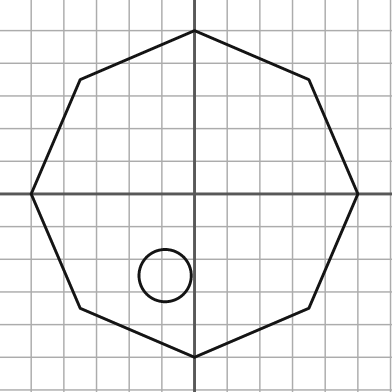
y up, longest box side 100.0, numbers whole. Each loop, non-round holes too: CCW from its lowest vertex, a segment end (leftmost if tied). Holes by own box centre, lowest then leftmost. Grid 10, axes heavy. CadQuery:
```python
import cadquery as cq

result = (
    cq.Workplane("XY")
    .moveTo(0.0, -50.0)
    .lineTo(35.0, -35.0)
    .lineTo(50.0, 0.0)
    .lineTo(35.0, 35.0)
    .lineTo(0.0, 50.0)
    .lineTo(-35.0, 35.0)
    .lineTo(-50.0, 0.0)
    .lineTo(-35.0, -35.0)
    .close()
    .moveTo(-9.0, -25.0)
    .circle(8.0)
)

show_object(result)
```